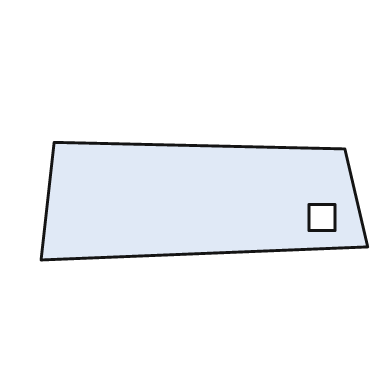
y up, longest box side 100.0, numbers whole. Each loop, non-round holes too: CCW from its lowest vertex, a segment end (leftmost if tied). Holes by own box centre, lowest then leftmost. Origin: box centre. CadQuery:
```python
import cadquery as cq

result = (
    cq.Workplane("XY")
    .moveTo(-50.0, -18.0)
    .lineTo(50.0, -14.0)
    .lineTo(43.0, 16.0)
    .lineTo(-46.0, 18.0)
    .close()
    .moveTo(32.0, -9.0)
    .lineTo(40.0, -9.0)
    .lineTo(40.0, -1.0)
    .lineTo(32.0, -1.0)
    .close()
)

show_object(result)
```